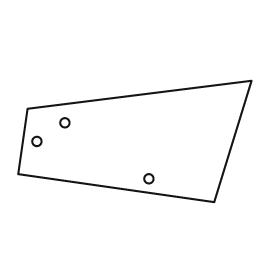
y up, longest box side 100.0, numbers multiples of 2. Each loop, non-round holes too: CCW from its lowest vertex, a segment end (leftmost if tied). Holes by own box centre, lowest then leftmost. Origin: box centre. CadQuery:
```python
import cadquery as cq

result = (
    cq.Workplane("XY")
    .moveTo(34.0, -26.0)
    .lineTo(50.0, 26.0)
    .lineTo(-46.0, 14.0)
    .lineTo(-50.0, -14.0)
    .close()
    .moveTo(6.0, -16.0)
    .circle(2.0)
    .moveTo(-42.0, 0.0)
    .circle(2.0)
    .moveTo(-30.0, 8.0)
    .circle(2.0)
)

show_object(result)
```